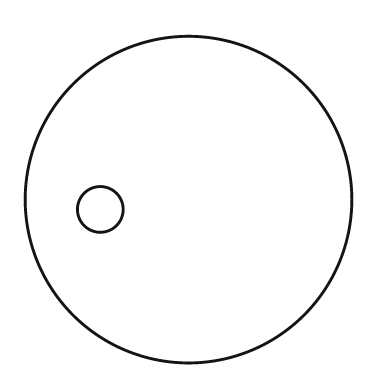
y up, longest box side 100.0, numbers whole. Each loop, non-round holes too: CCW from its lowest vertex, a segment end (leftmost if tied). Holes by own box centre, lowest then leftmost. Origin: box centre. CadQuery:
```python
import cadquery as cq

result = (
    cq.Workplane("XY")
    .moveTo(0.0, 0.0)
    .circle(50.0)
    .moveTo(-27.0, -3.0)
    .circle(7.0)
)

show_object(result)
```